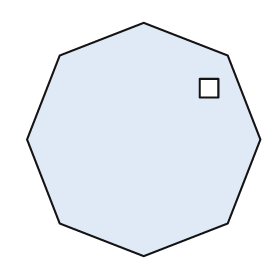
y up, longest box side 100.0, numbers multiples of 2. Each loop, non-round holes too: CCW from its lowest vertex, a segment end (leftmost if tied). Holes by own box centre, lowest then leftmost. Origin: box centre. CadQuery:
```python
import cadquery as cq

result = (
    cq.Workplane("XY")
    .moveTo(0.0, -50.0)
    .lineTo(36.0, -36.0)
    .lineTo(50.0, 0.0)
    .lineTo(36.0, 36.0)
    .lineTo(0.0, 50.0)
    .lineTo(-36.0, 36.0)
    .lineTo(-50.0, 0.0)
    .lineTo(-36.0, -36.0)
    .close()
    .moveTo(24.0, 18.0)
    .lineTo(32.0, 18.0)
    .lineTo(32.0, 26.0)
    .lineTo(24.0, 26.0)
    .close()
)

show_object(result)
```